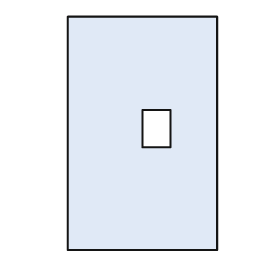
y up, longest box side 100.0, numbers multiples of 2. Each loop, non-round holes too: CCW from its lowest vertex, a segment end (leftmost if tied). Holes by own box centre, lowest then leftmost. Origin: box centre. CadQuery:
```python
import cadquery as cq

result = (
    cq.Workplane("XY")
    .moveTo(-32.0, -50.0)
    .lineTo(32.0, -50.0)
    .lineTo(32.0, 50.0)
    .lineTo(-32.0, 50.0)
    .close()
    .moveTo(0.0, -6.0)
    .lineTo(12.0, -6.0)
    .lineTo(12.0, 10.0)
    .lineTo(0.0, 10.0)
    .close()
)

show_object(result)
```